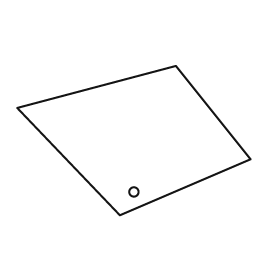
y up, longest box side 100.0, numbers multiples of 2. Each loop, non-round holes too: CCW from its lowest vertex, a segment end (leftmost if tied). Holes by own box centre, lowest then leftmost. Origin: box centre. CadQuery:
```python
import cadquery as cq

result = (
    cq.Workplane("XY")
    .moveTo(-6.0, -32.0)
    .lineTo(50.0, -8.0)
    .lineTo(18.0, 32.0)
    .lineTo(-50.0, 14.0)
    .close()
    .moveTo(0.0, -22.0)
    .circle(2.0)
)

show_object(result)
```